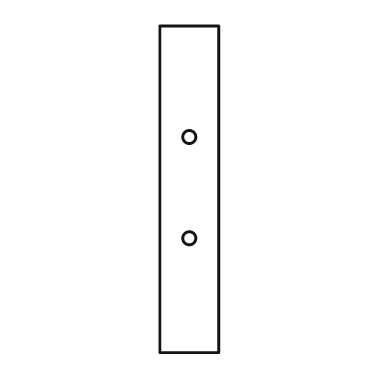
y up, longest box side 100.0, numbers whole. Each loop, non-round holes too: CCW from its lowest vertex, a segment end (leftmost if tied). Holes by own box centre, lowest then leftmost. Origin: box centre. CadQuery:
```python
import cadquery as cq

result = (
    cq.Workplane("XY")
    .moveTo(-9.0, -50.0)
    .lineTo(9.0, -50.0)
    .lineTo(9.0, 50.0)
    .lineTo(-9.0, 50.0)
    .close()
    .moveTo(0.0, -15.0)
    .circle(2.0)
    .moveTo(0.0, 16.0)
    .circle(2.0)
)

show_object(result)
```